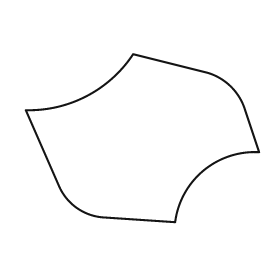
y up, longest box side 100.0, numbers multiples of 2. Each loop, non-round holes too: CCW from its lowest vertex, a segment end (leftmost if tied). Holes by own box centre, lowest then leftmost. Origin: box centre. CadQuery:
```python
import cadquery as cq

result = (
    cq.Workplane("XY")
    .moveTo(14.0, -36.0)
    .threePointArc((26.0, -14.0), (50.0, -6.0))
    .lineTo(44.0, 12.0)
    .threePointArc((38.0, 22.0), (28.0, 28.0))
    .lineTo(-4.0, 36.0)
    .threePointArc((-24.0, 18.0), (-50.0, 12.0))
    .lineTo(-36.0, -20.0)
    .threePointArc((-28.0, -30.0), (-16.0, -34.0))
    .close()
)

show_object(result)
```